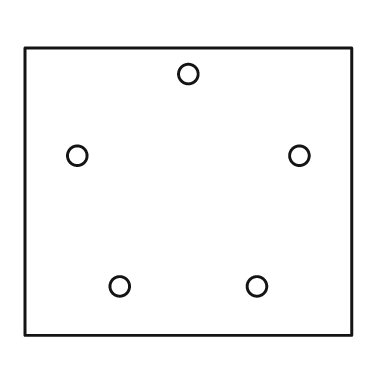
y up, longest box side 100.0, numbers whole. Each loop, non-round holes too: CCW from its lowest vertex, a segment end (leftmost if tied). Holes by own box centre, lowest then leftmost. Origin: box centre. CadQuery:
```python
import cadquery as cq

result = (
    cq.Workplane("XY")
    .moveTo(-50.0, -44.0)
    .lineTo(50.0, -44.0)
    .lineTo(50.0, 44.0)
    .lineTo(-50.0, 44.0)
    .close()
    .moveTo(-21.0, -29.0)
    .circle(3.0)
    .moveTo(21.0, -29.0)
    .circle(3.0)
    .moveTo(-34.0, 11.0)
    .circle(3.0)
    .moveTo(34.0, 11.0)
    .circle(3.0)
    .moveTo(0.0, 36.0)
    .circle(3.0)
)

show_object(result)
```